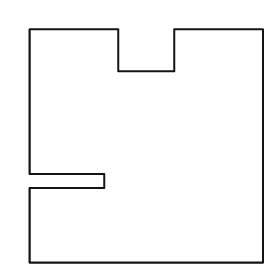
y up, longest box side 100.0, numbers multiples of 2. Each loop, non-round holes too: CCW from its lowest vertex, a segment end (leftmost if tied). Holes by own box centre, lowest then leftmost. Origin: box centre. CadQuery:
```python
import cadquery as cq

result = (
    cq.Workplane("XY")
    .moveTo(-50.0, -50.0)
    .lineTo(50.0, -50.0)
    .lineTo(50.0, 50.0)
    .lineTo(12.0, 50.0)
    .lineTo(12.0, 32.0)
    .lineTo(-12.0, 32.0)
    .lineTo(-12.0, 50.0)
    .lineTo(-50.0, 50.0)
    .lineTo(-50.0, -12.0)
    .lineTo(-18.0, -12.0)
    .lineTo(-18.0, -18.0)
    .lineTo(-50.0, -18.0)
    .close()
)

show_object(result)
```